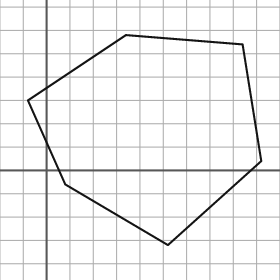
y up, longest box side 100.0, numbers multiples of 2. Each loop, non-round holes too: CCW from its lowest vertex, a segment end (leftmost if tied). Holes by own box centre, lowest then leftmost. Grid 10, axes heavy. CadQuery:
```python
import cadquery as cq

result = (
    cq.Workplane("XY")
    .moveTo(52.0, -32.0)
    .lineTo(92.0, 4.0)
    .lineTo(84.0, 54.0)
    .lineTo(34.0, 58.0)
    .lineTo(-8.0, 30.0)
    .lineTo(8.0, -6.0)
    .close()
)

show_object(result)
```